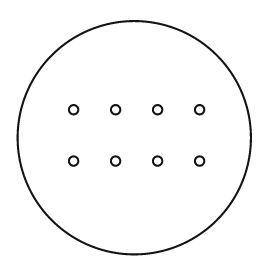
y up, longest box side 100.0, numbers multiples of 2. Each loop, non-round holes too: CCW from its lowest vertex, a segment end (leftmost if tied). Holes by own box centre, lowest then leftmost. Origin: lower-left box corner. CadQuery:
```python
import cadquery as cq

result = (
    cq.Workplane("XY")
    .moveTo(50.0, 50.0)
    .circle(50.0)
    .moveTo(24.0, 40.0)
    .circle(2.0)
    .moveTo(42.0, 40.0)
    .circle(2.0)
    .moveTo(60.0, 40.0)
    .circle(2.0)
    .moveTo(78.0, 40.0)
    .circle(2.0)
    .moveTo(24.0, 62.0)
    .circle(2.0)
    .moveTo(42.0, 62.0)
    .circle(2.0)
    .moveTo(60.0, 62.0)
    .circle(2.0)
    .moveTo(78.0, 62.0)
    .circle(2.0)
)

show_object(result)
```